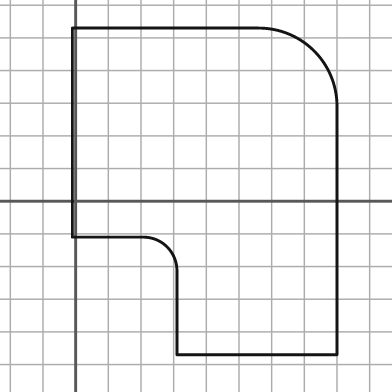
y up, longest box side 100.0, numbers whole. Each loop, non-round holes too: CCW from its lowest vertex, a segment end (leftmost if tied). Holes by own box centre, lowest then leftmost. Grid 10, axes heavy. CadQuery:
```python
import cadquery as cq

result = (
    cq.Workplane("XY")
    .moveTo(31.0, -47.0)
    .lineTo(80.0, -47.0)
    .lineTo(80.0, 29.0)
    .threePointArc((73.0, 46.0), (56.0, 53.0))
    .lineTo(-1.0, 53.0)
    .lineTo(-1.0, -11.0)
    .lineTo(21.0, -11.0)
    .threePointArc((28.0, -14.0), (31.0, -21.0))
    .close()
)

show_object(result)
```